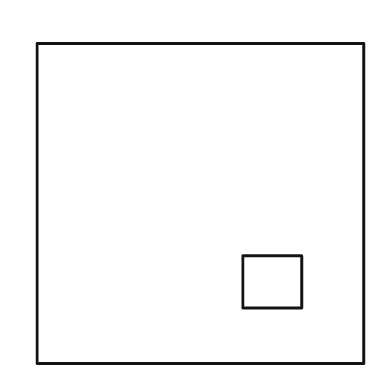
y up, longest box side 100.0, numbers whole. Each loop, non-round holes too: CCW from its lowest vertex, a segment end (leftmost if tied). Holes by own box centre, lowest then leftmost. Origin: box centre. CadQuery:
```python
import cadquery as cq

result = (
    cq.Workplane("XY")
    .moveTo(-50.0, -49.0)
    .lineTo(50.0, -49.0)
    .lineTo(50.0, 49.0)
    .lineTo(-50.0, 49.0)
    .close()
    .moveTo(13.0, -32.0)
    .lineTo(31.0, -32.0)
    .lineTo(31.0, -16.0)
    .lineTo(13.0, -16.0)
    .close()
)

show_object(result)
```